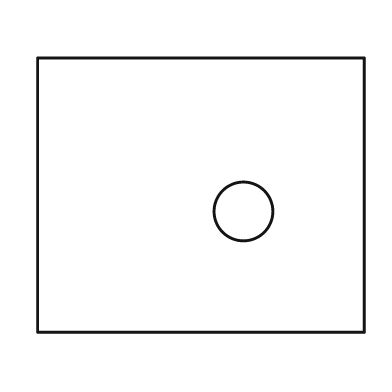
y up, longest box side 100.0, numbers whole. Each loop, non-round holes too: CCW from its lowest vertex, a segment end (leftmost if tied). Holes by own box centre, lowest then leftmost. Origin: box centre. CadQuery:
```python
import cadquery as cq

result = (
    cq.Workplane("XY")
    .moveTo(-50.0, -42.0)
    .lineTo(50.0, -42.0)
    .lineTo(50.0, 42.0)
    .lineTo(-50.0, 42.0)
    .close()
    .moveTo(13.0, -5.0)
    .circle(9.0)
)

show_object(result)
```